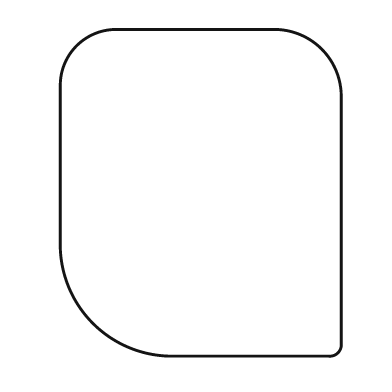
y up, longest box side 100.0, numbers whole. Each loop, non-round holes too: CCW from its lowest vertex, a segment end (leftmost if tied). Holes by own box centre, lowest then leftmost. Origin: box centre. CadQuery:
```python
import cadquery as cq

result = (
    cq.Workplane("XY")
    .moveTo(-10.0, -50.0)
    .lineTo(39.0, -50.0)
    .threePointArc((42.0, -49.0), (43.0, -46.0))
    .lineTo(43.0, 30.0)
    .threePointArc((37.0, 44.0), (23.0, 50.0))
    .lineTo(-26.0, 50.0)
    .threePointArc((-38.0, 45.0), (-43.0, 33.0))
    .lineTo(-43.0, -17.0)
    .threePointArc((-33.0, -40.0), (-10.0, -50.0))
    .close()
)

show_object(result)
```